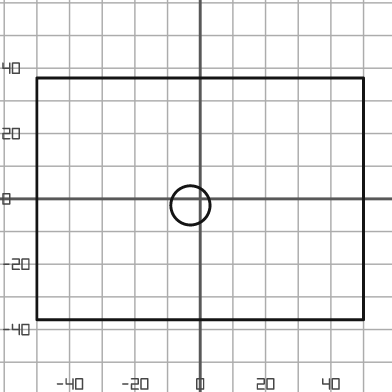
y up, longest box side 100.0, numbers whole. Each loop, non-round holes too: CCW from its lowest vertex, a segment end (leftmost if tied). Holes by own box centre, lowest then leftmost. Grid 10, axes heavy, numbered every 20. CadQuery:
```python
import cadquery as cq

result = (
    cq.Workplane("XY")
    .moveTo(-50.0, -37.0)
    .lineTo(50.0, -37.0)
    .lineTo(50.0, 37.0)
    .lineTo(-50.0, 37.0)
    .close()
    .moveTo(-3.0, -2.0)
    .circle(6.0)
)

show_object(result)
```